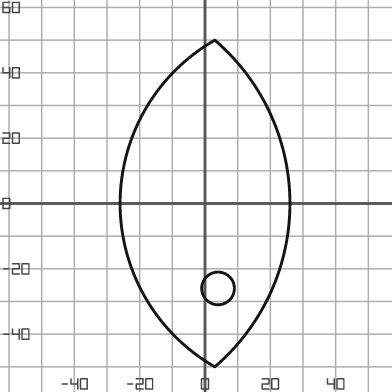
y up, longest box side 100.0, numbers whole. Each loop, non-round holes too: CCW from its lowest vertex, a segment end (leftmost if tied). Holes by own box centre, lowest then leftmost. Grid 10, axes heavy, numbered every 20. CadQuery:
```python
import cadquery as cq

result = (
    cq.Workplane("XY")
    .moveTo(3.0, -50.0)
    .threePointArc((26.0, 0.0), (3.0, 50.0))
    .threePointArc((-26.0, 0.0), (3.0, -50.0))
    .close()
    .moveTo(4.0, -26.0)
    .circle(5.0)
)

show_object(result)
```